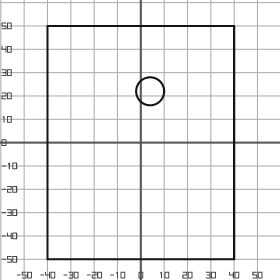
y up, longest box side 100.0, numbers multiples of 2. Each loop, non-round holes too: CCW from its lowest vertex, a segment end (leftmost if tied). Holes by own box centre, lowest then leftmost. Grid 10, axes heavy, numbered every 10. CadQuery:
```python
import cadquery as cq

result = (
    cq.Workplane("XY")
    .moveTo(-40.0, -50.0)
    .lineTo(40.0, -50.0)
    .lineTo(40.0, 50.0)
    .lineTo(-40.0, 50.0)
    .close()
    .moveTo(4.0, 22.0)
    .circle(6.0)
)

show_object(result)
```